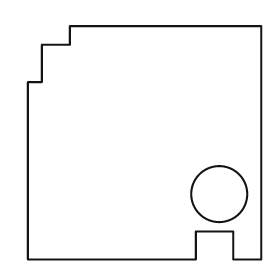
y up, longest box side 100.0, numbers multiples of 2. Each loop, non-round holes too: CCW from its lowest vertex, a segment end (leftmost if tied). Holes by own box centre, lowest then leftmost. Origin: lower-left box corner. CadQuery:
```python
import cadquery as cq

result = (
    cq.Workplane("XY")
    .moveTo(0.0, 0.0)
    .lineTo(72.0, 0.0)
    .lineTo(72.0, 12.0)
    .lineTo(88.0, 12.0)
    .lineTo(88.0, 0.0)
    .lineTo(100.0, 0.0)
    .lineTo(100.0, 100.0)
    .lineTo(18.0, 100.0)
    .lineTo(18.0, 92.0)
    .lineTo(6.0, 92.0)
    .lineTo(6.0, 76.0)
    .lineTo(0.0, 76.0)
    .close()
    .moveTo(82.0, 28.0)
    .circle(12.0)
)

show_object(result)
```